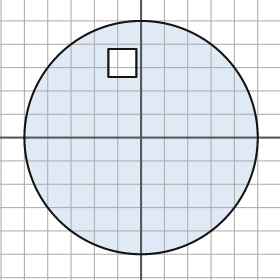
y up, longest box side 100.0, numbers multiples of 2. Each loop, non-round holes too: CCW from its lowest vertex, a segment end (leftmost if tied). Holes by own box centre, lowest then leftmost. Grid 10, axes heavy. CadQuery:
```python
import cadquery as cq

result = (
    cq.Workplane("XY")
    .moveTo(0.0, 0.0)
    .circle(50.0)
    .moveTo(-14.0, 26.0)
    .lineTo(-2.0, 26.0)
    .lineTo(-2.0, 38.0)
    .lineTo(-14.0, 38.0)
    .close()
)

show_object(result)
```